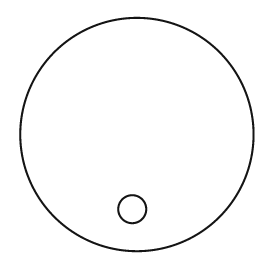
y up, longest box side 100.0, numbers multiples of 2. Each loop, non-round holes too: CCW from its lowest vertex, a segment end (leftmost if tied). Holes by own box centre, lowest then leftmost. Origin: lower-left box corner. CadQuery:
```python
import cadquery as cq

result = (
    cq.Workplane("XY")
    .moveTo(50.0, 50.0)
    .circle(50.0)
    .moveTo(48.0, 18.0)
    .circle(6.0)
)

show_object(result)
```